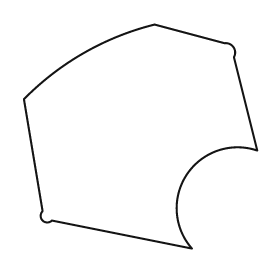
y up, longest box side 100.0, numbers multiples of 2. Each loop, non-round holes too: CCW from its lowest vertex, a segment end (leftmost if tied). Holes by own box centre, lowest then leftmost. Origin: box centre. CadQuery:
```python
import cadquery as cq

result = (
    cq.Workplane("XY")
    .moveTo(22.0, -48.0)
    .threePointArc((20.0, -16.0), (50.0, -6.0))
    .lineTo(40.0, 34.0)
    .threePointArc((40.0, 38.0), (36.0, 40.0))
    .lineTo(6.0, 48.0)
    .threePointArc((-24.0, 36.0), (-50.0, 16.0))
    .lineTo(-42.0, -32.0)
    .threePointArc((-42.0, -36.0), (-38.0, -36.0))
    .close()
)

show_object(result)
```